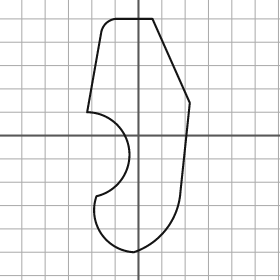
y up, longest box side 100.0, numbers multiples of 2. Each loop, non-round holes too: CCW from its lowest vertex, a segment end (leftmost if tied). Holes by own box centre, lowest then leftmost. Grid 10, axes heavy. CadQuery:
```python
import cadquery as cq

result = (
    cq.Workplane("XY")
    .moveTo(-2.0, -50.0)
    .threePointArc((12.0, -40.0), (18.0, -24.0))
    .lineTo(22.0, 14.0)
    .lineTo(6.0, 50.0)
    .lineTo(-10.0, 50.0)
    .threePointArc((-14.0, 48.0), (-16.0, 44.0))
    .lineTo(-22.0, 10.0)
    .threePointArc((-4.0, -6.0), (-18.0, -26.0))
    .threePointArc((-16.0, -42.0), (-2.0, -50.0))
    .close()
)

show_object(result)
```